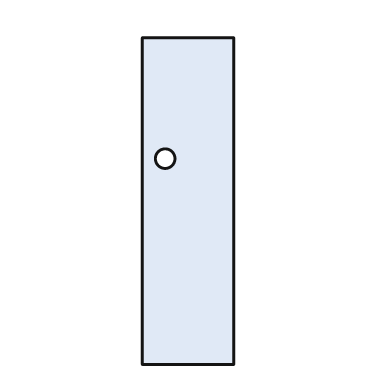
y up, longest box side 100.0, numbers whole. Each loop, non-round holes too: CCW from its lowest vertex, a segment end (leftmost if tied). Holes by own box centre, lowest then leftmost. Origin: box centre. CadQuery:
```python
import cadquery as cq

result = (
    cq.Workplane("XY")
    .moveTo(-14.0, -50.0)
    .lineTo(14.0, -50.0)
    .lineTo(14.0, 50.0)
    .lineTo(-14.0, 50.0)
    .close()
    .moveTo(-7.0, 13.0)
    .circle(3.0)
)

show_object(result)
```